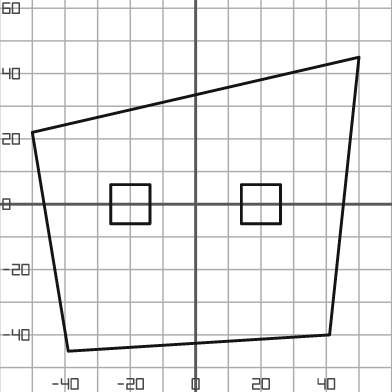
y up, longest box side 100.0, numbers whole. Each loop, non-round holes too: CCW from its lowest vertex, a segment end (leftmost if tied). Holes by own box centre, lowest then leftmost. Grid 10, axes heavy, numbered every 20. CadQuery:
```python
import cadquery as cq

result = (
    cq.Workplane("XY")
    .moveTo(-39.0, -45.0)
    .lineTo(41.0, -40.0)
    .lineTo(50.0, 45.0)
    .lineTo(-50.0, 22.0)
    .close()
    .moveTo(-26.0, -6.0)
    .lineTo(-14.0, -6.0)
    .lineTo(-14.0, 6.0)
    .lineTo(-26.0, 6.0)
    .close()
    .moveTo(14.0, -6.0)
    .lineTo(26.0, -6.0)
    .lineTo(26.0, 6.0)
    .lineTo(14.0, 6.0)
    .close()
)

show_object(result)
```